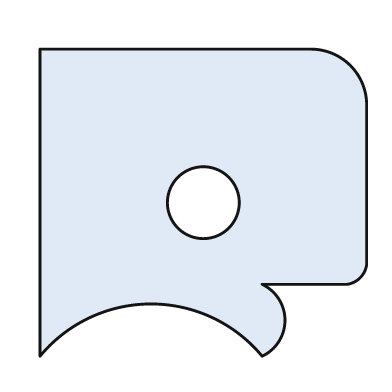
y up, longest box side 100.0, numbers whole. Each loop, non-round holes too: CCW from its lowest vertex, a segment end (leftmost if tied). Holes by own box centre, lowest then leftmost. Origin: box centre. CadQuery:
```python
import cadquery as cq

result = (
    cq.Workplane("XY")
    .moveTo(-50.0, -47.0)
    .threePointArc((-16.0, -31.0), (18.0, -47.0))
    .threePointArc((25.0, -36.0), (18.0, -25.0))
    .lineTo(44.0, -25.0)
    .threePointArc((48.0, -23.0), (50.0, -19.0))
    .lineTo(50.0, 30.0)
    .threePointArc((45.0, 42.0), (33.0, 47.0))
    .lineTo(-50.0, 47.0)
    .close()
    .moveTo(0.0, 0.0)
    .circle(11.0)
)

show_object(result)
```